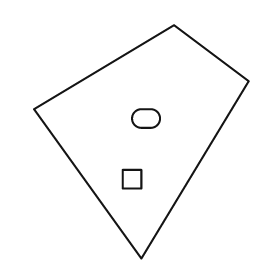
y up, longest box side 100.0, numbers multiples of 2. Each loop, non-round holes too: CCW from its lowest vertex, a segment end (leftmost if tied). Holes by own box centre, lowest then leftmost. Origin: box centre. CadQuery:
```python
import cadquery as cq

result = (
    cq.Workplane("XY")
    .moveTo(0.0, -50.0)
    .lineTo(46.0, 26.0)
    .lineTo(14.0, 50.0)
    .lineTo(-46.0, 14.0)
    .close()
    .moveTo(-8.0, -20.0)
    .lineTo(0.0, -20.0)
    .lineTo(0.0, -12.0)
    .lineTo(-8.0, -12.0)
    .close()
    .moveTo(0.0, 6.0)
    .lineTo(4.0, 6.0)
    .threePointArc((8.0, 10.0), (4.0, 14.0))
    .lineTo(0.0, 14.0)
    .threePointArc((-4.0, 10.0), (0.0, 6.0))
    .close()
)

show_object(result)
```